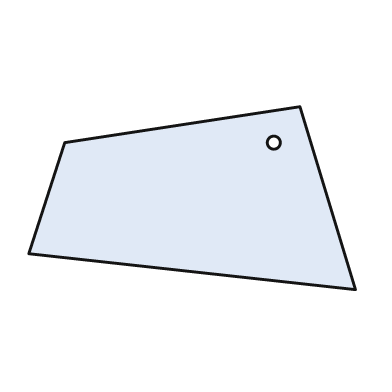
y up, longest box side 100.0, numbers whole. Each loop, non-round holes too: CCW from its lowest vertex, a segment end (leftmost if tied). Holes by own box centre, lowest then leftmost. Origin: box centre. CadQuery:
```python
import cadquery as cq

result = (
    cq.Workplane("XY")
    .moveTo(50.0, -28.0)
    .lineTo(33.0, 28.0)
    .lineTo(-39.0, 17.0)
    .lineTo(-50.0, -17.0)
    .close()
    .moveTo(25.0, 17.0)
    .circle(2.0)
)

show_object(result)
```